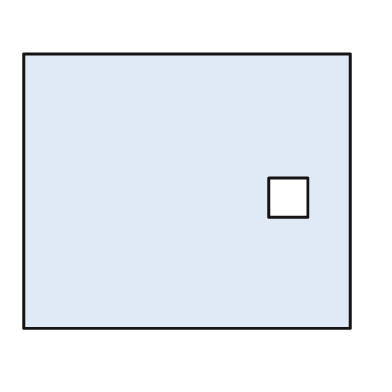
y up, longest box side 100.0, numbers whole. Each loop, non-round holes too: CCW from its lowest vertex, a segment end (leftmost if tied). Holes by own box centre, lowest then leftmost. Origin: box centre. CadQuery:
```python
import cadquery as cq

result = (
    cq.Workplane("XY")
    .moveTo(-50.0, -42.0)
    .lineTo(50.0, -42.0)
    .lineTo(50.0, 42.0)
    .lineTo(-50.0, 42.0)
    .close()
    .moveTo(25.0, -8.0)
    .lineTo(37.0, -8.0)
    .lineTo(37.0, 4.0)
    .lineTo(25.0, 4.0)
    .close()
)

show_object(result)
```